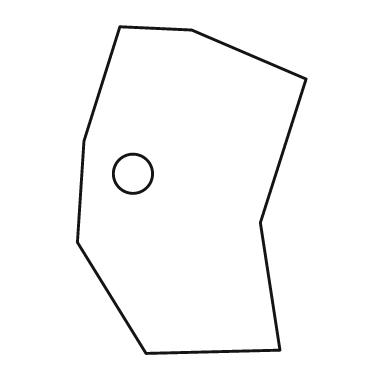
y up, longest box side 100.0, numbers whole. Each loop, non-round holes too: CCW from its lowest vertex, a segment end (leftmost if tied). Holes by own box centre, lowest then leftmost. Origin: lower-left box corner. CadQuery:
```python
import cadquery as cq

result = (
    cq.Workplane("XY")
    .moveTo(21.0, 0.0)
    .lineTo(62.0, 1.0)
    .lineTo(56.0, 40.0)
    .lineTo(70.0, 84.0)
    .lineTo(35.0, 99.0)
    .lineTo(13.0, 100.0)
    .lineTo(2.0, 65.0)
    .lineTo(0.0, 34.0)
    .close()
    .moveTo(17.0, 55.0)
    .circle(6.0)
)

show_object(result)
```